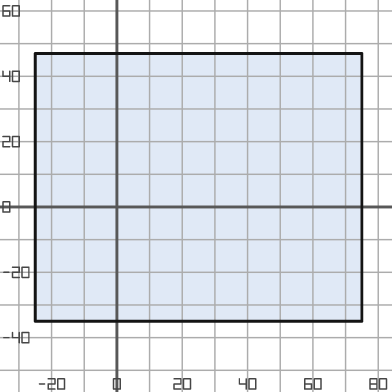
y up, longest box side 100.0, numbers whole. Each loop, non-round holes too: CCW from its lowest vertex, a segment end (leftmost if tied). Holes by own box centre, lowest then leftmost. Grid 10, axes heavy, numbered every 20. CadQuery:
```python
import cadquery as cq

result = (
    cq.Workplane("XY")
    .moveTo(-25.0, -35.0)
    .lineTo(75.0, -35.0)
    .lineTo(75.0, 47.0)
    .lineTo(-25.0, 47.0)
    .close()
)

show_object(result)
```